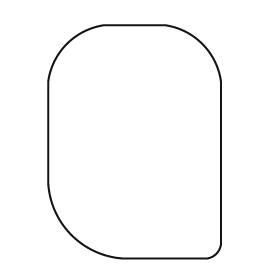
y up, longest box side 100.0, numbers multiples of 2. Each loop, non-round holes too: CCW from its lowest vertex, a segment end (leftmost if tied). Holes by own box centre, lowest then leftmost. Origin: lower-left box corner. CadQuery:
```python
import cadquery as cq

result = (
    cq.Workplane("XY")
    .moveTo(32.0, 0.0)
    .lineTo(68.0, 0.0)
    .threePointArc((72.0, 2.0), (74.0, 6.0))
    .lineTo(74.0, 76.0)
    .threePointArc((66.0, 92.0), (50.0, 100.0))
    .lineTo(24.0, 100.0)
    .threePointArc((8.0, 92.0), (0.0, 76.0))
    .lineTo(0.0, 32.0)
    .threePointArc((10.0, 10.0), (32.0, 0.0))
    .close()
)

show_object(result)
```